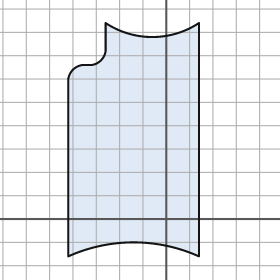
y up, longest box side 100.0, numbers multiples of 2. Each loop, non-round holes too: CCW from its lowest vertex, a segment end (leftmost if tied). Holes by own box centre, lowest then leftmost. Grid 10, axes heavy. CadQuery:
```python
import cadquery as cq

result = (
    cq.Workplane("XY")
    .moveTo(-42.0, -16.0)
    .threePointArc((-14.0, -10.0), (14.0, -16.0))
    .lineTo(14.0, 84.0)
    .threePointArc((-6.0, 78.0), (-26.0, 84.0))
    .lineTo(-26.0, 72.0)
    .threePointArc((-28.0, 68.0), (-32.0, 66.0))
    .lineTo(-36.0, 66.0)
    .threePointArc((-40.0, 64.0), (-42.0, 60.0))
    .close()
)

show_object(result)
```